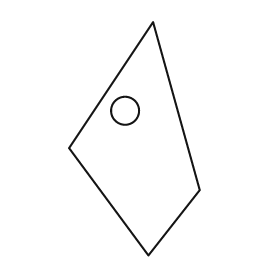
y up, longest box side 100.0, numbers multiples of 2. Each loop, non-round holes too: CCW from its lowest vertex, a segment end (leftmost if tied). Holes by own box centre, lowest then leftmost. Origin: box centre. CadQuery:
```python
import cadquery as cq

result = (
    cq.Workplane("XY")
    .moveTo(6.0, -50.0)
    .lineTo(28.0, -22.0)
    .lineTo(8.0, 50.0)
    .lineTo(-28.0, -4.0)
    .close()
    .moveTo(-4.0, 12.0)
    .circle(6.0)
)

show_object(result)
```